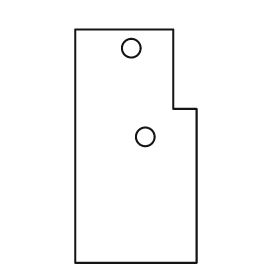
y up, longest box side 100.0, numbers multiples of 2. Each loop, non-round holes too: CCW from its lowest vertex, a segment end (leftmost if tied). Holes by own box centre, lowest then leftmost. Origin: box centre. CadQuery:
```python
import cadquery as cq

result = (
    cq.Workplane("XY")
    .moveTo(-26.0, -50.0)
    .lineTo(26.0, -50.0)
    .lineTo(26.0, 16.0)
    .lineTo(16.0, 16.0)
    .lineTo(16.0, 50.0)
    .lineTo(-26.0, 50.0)
    .close()
    .moveTo(4.0, 4.0)
    .circle(4.0)
    .moveTo(-2.0, 42.0)
    .circle(4.0)
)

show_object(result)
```